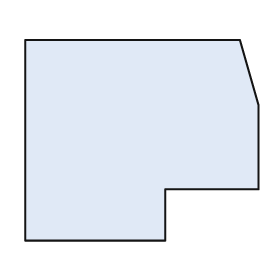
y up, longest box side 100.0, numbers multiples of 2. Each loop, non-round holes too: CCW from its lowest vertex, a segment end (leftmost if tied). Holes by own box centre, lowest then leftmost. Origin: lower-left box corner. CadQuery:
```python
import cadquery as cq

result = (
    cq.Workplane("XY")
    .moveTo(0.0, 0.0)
    .lineTo(60.0, 0.0)
    .lineTo(60.0, 22.0)
    .lineTo(100.0, 22.0)
    .lineTo(100.0, 58.0)
    .lineTo(92.0, 86.0)
    .lineTo(0.0, 86.0)
    .close()
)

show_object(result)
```